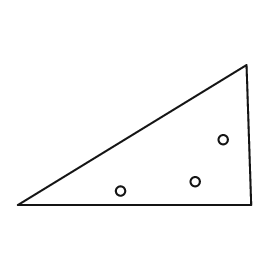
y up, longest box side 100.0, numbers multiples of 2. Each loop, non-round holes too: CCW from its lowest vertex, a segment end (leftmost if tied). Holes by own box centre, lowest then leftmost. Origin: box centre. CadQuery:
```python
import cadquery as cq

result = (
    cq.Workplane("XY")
    .moveTo(-50.0, -30.0)
    .lineTo(50.0, -30.0)
    .lineTo(48.0, 30.0)
    .close()
    .moveTo(-6.0, -24.0)
    .circle(2.0)
    .moveTo(26.0, -20.0)
    .circle(2.0)
    .moveTo(38.0, -2.0)
    .circle(2.0)
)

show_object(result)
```